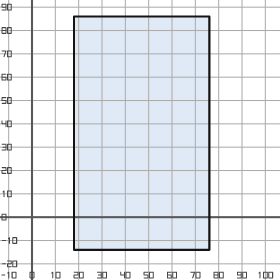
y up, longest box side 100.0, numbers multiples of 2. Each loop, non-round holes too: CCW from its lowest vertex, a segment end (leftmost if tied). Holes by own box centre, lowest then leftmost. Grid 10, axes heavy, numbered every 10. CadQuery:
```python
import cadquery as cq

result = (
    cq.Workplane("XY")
    .moveTo(18.0, -14.0)
    .lineTo(76.0, -14.0)
    .lineTo(76.0, 86.0)
    .lineTo(18.0, 86.0)
    .close()
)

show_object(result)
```